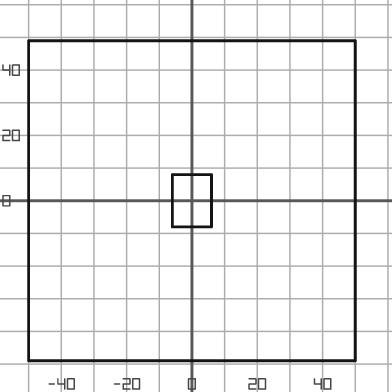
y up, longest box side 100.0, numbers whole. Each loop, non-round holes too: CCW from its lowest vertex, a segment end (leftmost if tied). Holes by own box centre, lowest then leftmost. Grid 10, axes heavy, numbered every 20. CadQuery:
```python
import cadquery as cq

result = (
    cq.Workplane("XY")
    .moveTo(-50.0, -49.0)
    .lineTo(50.0, -49.0)
    .lineTo(50.0, 49.0)
    .lineTo(-50.0, 49.0)
    .close()
    .moveTo(-6.0, -8.0)
    .lineTo(6.0, -8.0)
    .lineTo(6.0, 8.0)
    .lineTo(-6.0, 8.0)
    .close()
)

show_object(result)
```